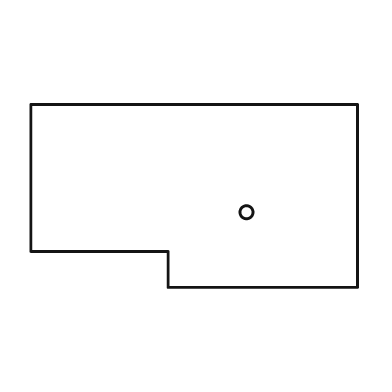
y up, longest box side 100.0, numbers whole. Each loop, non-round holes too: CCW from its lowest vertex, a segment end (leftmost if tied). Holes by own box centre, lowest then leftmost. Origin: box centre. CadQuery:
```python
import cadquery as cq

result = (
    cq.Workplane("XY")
    .moveTo(-8.0, -28.0)
    .lineTo(50.0, -28.0)
    .lineTo(50.0, 28.0)
    .lineTo(-50.0, 28.0)
    .lineTo(-50.0, -17.0)
    .lineTo(-8.0, -17.0)
    .close()
    .moveTo(16.0, -5.0)
    .circle(2.0)
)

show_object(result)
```